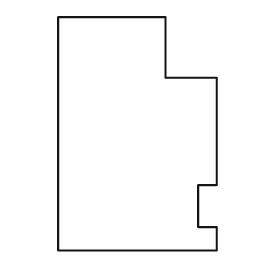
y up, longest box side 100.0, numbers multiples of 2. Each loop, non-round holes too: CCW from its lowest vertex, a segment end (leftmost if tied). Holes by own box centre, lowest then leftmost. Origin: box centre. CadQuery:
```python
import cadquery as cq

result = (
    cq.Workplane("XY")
    .moveTo(-34.0, -50.0)
    .lineTo(34.0, -50.0)
    .lineTo(34.0, -40.0)
    .lineTo(26.0, -40.0)
    .lineTo(26.0, -22.0)
    .lineTo(34.0, -22.0)
    .lineTo(34.0, 24.0)
    .lineTo(12.0, 24.0)
    .lineTo(12.0, 50.0)
    .lineTo(-34.0, 50.0)
    .close()
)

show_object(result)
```